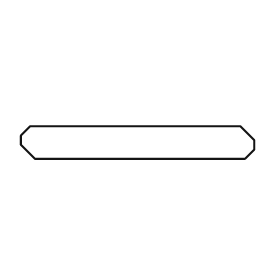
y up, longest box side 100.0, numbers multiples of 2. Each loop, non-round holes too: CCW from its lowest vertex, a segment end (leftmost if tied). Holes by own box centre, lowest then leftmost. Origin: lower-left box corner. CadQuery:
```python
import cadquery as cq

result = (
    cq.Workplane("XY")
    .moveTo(6.0, 0.0)
    .lineTo(96.0, 0.0)
    .lineTo(100.0, 4.0)
    .lineTo(100.0, 8.0)
    .lineTo(94.0, 14.0)
    .lineTo(4.0, 14.0)
    .lineTo(0.0, 10.0)
    .lineTo(0.0, 6.0)
    .close()
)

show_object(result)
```